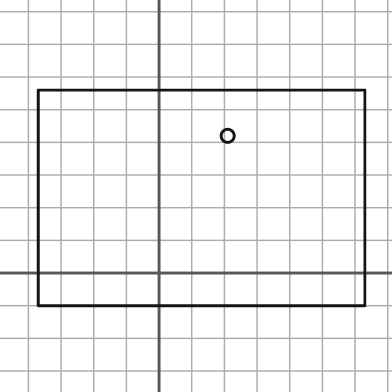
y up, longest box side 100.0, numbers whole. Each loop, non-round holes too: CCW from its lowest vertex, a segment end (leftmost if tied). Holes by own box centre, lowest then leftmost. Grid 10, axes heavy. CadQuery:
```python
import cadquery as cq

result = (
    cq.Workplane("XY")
    .moveTo(-37.0, -10.0)
    .lineTo(63.0, -10.0)
    .lineTo(63.0, 56.0)
    .lineTo(-37.0, 56.0)
    .close()
    .moveTo(21.0, 42.0)
    .circle(2.0)
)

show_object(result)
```